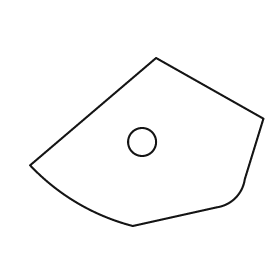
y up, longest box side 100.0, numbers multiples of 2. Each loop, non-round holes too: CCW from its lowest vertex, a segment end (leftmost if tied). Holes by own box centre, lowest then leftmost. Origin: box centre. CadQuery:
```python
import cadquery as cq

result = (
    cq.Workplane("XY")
    .moveTo(-6.0, -36.0)
    .lineTo(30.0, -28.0)
    .threePointArc((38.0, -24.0), (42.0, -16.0))
    .lineTo(50.0, 10.0)
    .lineTo(4.0, 36.0)
    .lineTo(-50.0, -10.0)
    .threePointArc((-30.0, -26.0), (-6.0, -36.0))
    .close()
    .moveTo(-2.0, 0.0)
    .circle(6.0)
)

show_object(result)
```